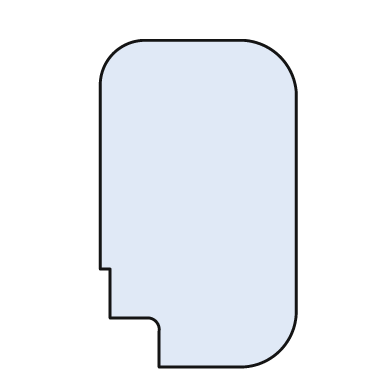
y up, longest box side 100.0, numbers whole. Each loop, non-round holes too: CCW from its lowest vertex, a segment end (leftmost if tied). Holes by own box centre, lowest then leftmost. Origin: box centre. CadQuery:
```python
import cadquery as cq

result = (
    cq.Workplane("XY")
    .moveTo(-12.0, -50.0)
    .lineTo(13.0, -50.0)
    .threePointArc((25.0, -45.0), (30.0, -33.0))
    .lineTo(30.0, 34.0)
    .threePointArc((25.0, 45.0), (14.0, 50.0))
    .lineTo(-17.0, 50.0)
    .threePointArc((-26.0, 46.0), (-30.0, 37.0))
    .lineTo(-30.0, -20.0)
    .lineTo(-27.0, -20.0)
    .lineTo(-27.0, -35.0)
    .lineTo(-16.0, -35.0)
    .threePointArc((-13.0, -36.0), (-12.0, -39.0))
    .close()
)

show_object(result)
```